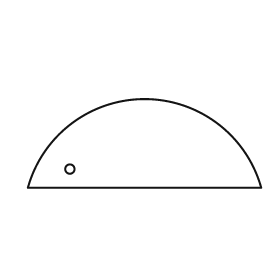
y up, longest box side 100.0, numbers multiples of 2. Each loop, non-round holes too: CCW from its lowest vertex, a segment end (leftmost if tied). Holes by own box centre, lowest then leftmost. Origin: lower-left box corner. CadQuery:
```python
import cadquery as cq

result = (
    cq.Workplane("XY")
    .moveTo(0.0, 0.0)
    .lineTo(100.0, 0.0)
    .threePointArc((50.0, 38.0), (0.0, 0.0))
    .close()
    .moveTo(18.0, 8.0)
    .circle(2.0)
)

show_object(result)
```